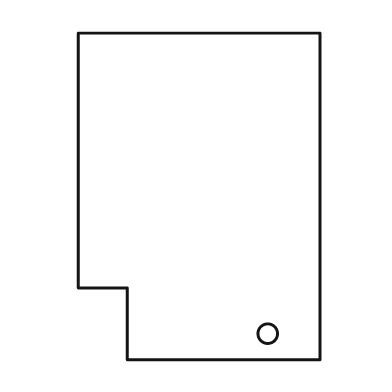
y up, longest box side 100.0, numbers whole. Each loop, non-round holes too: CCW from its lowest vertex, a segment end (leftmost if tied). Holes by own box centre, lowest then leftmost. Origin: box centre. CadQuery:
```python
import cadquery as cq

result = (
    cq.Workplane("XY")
    .moveTo(-22.0, -50.0)
    .lineTo(37.0, -50.0)
    .lineTo(37.0, 50.0)
    .lineTo(-37.0, 50.0)
    .lineTo(-37.0, -28.0)
    .lineTo(-22.0, -28.0)
    .close()
    .moveTo(21.0, -42.0)
    .circle(3.0)
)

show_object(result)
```